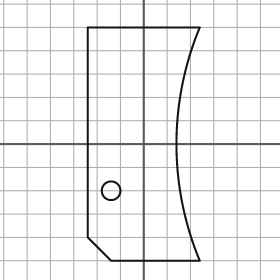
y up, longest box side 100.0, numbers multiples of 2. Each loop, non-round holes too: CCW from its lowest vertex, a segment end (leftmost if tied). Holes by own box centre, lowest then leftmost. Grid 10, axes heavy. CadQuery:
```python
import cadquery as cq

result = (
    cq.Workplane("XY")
    .moveTo(-14.0, -50.0)
    .lineTo(24.0, -50.0)
    .threePointArc((14.0, 0.0), (24.0, 50.0))
    .lineTo(-24.0, 50.0)
    .lineTo(-24.0, -40.0)
    .close()
    .moveTo(-14.0, -20.0)
    .circle(4.0)
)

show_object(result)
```